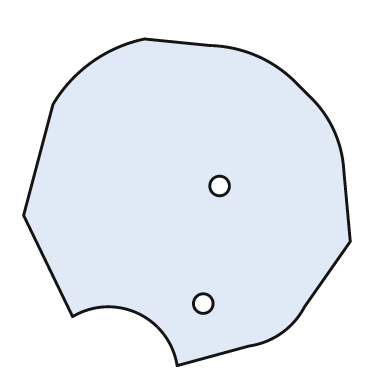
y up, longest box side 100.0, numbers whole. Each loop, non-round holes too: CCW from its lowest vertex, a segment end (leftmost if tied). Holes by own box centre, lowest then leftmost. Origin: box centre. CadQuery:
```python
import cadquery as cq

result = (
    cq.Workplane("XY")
    .moveTo(-3.0, -50.0)
    .lineTo(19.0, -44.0)
    .threePointArc((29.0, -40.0), (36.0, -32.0))
    .lineTo(50.0, -12.0)
    .lineTo(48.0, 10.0)
    .threePointArc((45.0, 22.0), (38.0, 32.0))
    .lineTo(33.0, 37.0)
    .threePointArc((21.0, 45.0), (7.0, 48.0))
    .lineTo(-13.0, 50.0)
    .threePointArc((-29.0, 43.0), (-41.0, 30.0))
    .lineTo(-50.0, -4.0)
    .lineTo(-35.0, -35.0)
    .threePointArc((-15.0, -34.0), (-3.0, -50.0))
    .close()
    .moveTo(5.0, -31.0)
    .circle(3.0)
    .moveTo(10.0, 5.0)
    .circle(3.0)
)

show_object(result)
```